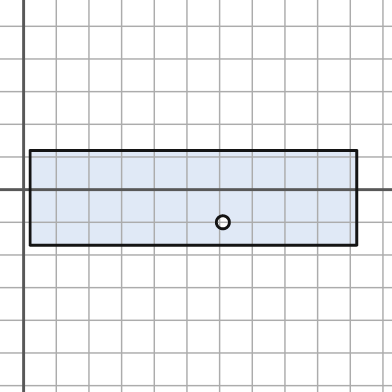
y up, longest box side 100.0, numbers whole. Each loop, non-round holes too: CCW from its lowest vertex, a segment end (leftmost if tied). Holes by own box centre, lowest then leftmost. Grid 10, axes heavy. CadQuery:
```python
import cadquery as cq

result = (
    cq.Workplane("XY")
    .moveTo(2.0, -17.0)
    .lineTo(102.0, -17.0)
    .lineTo(102.0, 12.0)
    .lineTo(2.0, 12.0)
    .close()
    .moveTo(61.0, -10.0)
    .circle(2.0)
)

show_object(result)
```